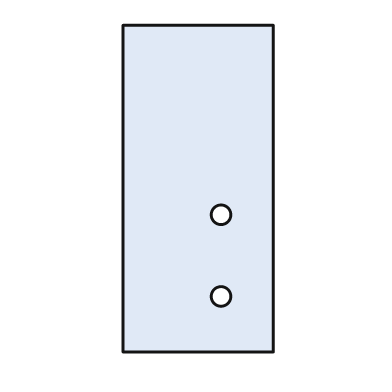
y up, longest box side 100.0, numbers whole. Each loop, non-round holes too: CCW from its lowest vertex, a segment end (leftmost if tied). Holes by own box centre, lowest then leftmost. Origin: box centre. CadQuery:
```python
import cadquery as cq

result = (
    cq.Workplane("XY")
    .moveTo(-23.0, -50.0)
    .lineTo(23.0, -50.0)
    .lineTo(23.0, 50.0)
    .lineTo(-23.0, 50.0)
    .close()
    .moveTo(7.0, -33.0)
    .circle(3.0)
    .moveTo(7.0, -8.0)
    .circle(3.0)
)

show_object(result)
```